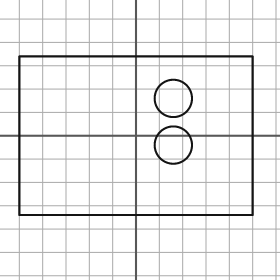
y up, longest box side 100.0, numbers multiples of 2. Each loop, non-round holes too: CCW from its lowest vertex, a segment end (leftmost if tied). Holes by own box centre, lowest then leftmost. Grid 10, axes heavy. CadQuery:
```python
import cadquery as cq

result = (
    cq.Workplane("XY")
    .moveTo(-50.0, -34.0)
    .lineTo(50.0, -34.0)
    .lineTo(50.0, 34.0)
    .lineTo(-50.0, 34.0)
    .close()
    .moveTo(16.0, -4.0)
    .circle(8.0)
    .moveTo(16.0, 16.0)
    .circle(8.0)
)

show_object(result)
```